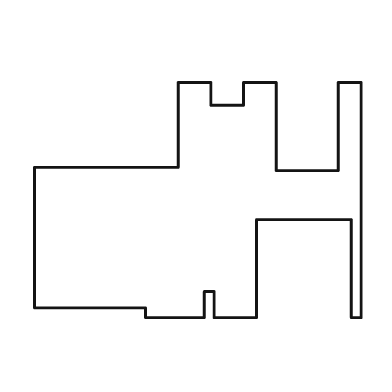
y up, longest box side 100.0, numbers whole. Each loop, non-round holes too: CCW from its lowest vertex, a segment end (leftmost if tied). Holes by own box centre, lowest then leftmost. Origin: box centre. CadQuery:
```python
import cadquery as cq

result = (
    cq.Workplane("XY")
    .moveTo(-16.0, -36.0)
    .lineTo(2.0, -36.0)
    .lineTo(2.0, -28.0)
    .lineTo(5.0, -28.0)
    .lineTo(5.0, -36.0)
    .lineTo(18.0, -36.0)
    .lineTo(18.0, -6.0)
    .lineTo(47.0, -6.0)
    .lineTo(47.0, -36.0)
    .lineTo(50.0, -36.0)
    .lineTo(50.0, 36.0)
    .lineTo(43.0, 36.0)
    .lineTo(43.0, 9.0)
    .lineTo(24.0, 9.0)
    .lineTo(24.0, 36.0)
    .lineTo(14.0, 36.0)
    .lineTo(14.0, 29.0)
    .lineTo(4.0, 29.0)
    .lineTo(4.0, 36.0)
    .lineTo(-6.0, 36.0)
    .lineTo(-6.0, 10.0)
    .lineTo(-50.0, 10.0)
    .lineTo(-50.0, -33.0)
    .lineTo(-16.0, -33.0)
    .close()
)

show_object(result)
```